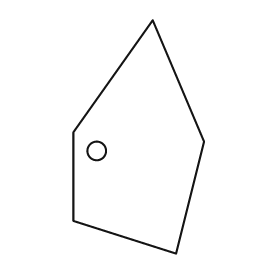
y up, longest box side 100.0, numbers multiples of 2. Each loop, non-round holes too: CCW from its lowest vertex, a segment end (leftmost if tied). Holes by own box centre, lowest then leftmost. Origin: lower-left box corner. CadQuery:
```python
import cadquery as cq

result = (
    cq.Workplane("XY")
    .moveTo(44.0, 0.0)
    .lineTo(56.0, 48.0)
    .lineTo(34.0, 100.0)
    .lineTo(0.0, 52.0)
    .lineTo(0.0, 14.0)
    .close()
    .moveTo(10.0, 44.0)
    .circle(4.0)
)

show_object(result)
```